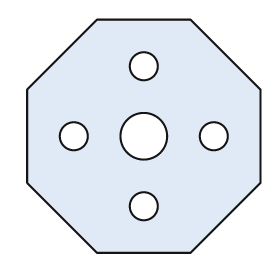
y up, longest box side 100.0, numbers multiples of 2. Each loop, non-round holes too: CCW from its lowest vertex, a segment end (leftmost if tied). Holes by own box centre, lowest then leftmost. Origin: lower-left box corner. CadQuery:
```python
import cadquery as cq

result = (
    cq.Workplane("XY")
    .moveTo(30.0, 0.0)
    .lineTo(70.0, 0.0)
    .lineTo(100.0, 30.0)
    .lineTo(100.0, 70.0)
    .lineTo(70.0, 100.0)
    .lineTo(30.0, 100.0)
    .lineTo(0.0, 70.0)
    .lineTo(0.0, 30.0)
    .close()
    .moveTo(50.0, 20.0)
    .circle(6.0)
    .moveTo(20.0, 50.0)
    .circle(6.0)
    .moveTo(50.0, 50.0)
    .circle(10.0)
    .moveTo(80.0, 50.0)
    .circle(6.0)
    .moveTo(50.0, 80.0)
    .circle(6.0)
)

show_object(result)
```